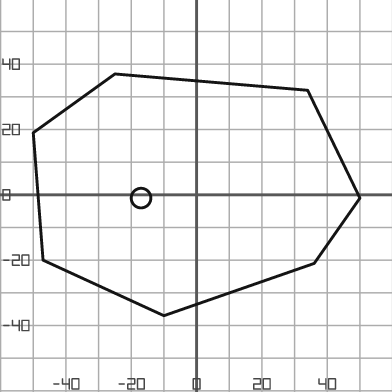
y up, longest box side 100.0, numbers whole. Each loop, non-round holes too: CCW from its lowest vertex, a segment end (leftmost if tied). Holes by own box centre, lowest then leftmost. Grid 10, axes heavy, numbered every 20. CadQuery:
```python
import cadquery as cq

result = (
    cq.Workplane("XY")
    .moveTo(-10.0, -37.0)
    .lineTo(36.0, -21.0)
    .lineTo(50.0, -1.0)
    .lineTo(34.0, 32.0)
    .lineTo(-25.0, 37.0)
    .lineTo(-50.0, 19.0)
    .lineTo(-47.0, -20.0)
    .close()
    .moveTo(-17.0, -1.0)
    .circle(3.0)
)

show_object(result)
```